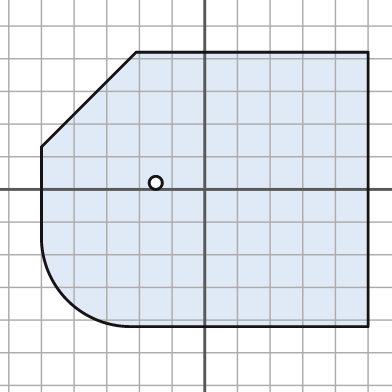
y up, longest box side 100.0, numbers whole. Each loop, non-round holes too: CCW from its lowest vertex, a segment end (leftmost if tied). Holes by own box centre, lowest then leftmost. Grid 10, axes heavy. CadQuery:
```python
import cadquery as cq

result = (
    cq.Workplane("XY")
    .moveTo(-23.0, -42.0)
    .lineTo(50.0, -42.0)
    .lineTo(50.0, 42.0)
    .lineTo(-21.0, 42.0)
    .lineTo(-50.0, 13.0)
    .lineTo(-50.0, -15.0)
    .threePointArc((-42.0, -34.0), (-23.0, -42.0))
    .close()
    .moveTo(-15.0, 2.0)
    .circle(2.0)
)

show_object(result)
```